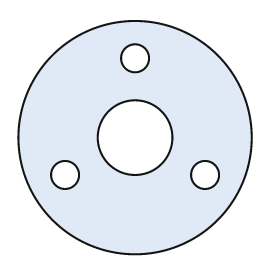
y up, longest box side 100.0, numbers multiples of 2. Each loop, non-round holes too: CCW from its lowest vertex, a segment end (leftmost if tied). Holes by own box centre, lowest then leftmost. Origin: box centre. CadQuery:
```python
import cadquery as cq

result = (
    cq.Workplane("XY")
    .moveTo(0.0, 0.0)
    .circle(50.0)
    .moveTo(-30.0, -16.0)
    .circle(6.0)
    .moveTo(30.0, -16.0)
    .circle(6.0)
    .moveTo(0.0, 0.0)
    .circle(16.0)
    .moveTo(0.0, 34.0)
    .circle(6.0)
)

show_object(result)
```